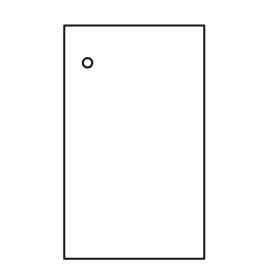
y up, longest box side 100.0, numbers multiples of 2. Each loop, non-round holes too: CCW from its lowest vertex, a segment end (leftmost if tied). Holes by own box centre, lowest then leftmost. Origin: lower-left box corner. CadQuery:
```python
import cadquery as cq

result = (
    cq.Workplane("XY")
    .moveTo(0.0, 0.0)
    .lineTo(60.0, 0.0)
    .lineTo(60.0, 100.0)
    .lineTo(0.0, 100.0)
    .close()
    .moveTo(10.0, 84.0)
    .circle(2.0)
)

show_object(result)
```